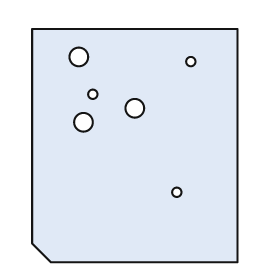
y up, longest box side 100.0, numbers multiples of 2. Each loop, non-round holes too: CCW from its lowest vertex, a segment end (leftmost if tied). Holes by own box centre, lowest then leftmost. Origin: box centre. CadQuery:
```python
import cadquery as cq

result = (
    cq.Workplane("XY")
    .moveTo(-36.0, -50.0)
    .lineTo(44.0, -50.0)
    .lineTo(44.0, 50.0)
    .lineTo(-44.0, 50.0)
    .lineTo(-44.0, -42.0)
    .close()
    .moveTo(18.0, -20.0)
    .circle(2.0)
    .moveTo(-22.0, 10.0)
    .circle(4.0)
    .moveTo(0.0, 16.0)
    .circle(4.0)
    .moveTo(-18.0, 22.0)
    .circle(2.0)
    .moveTo(24.0, 36.0)
    .circle(2.0)
    .moveTo(-24.0, 38.0)
    .circle(4.0)
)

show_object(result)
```